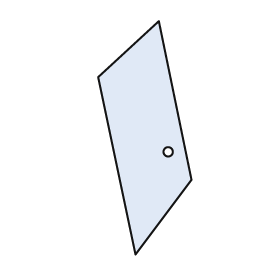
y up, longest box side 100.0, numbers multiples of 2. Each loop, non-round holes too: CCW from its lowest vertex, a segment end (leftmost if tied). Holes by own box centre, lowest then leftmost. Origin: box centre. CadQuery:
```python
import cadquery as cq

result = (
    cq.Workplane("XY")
    .moveTo(-4.0, -50.0)
    .lineTo(20.0, -18.0)
    .lineTo(6.0, 50.0)
    .lineTo(-20.0, 26.0)
    .close()
    .moveTo(10.0, -6.0)
    .circle(2.0)
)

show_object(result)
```